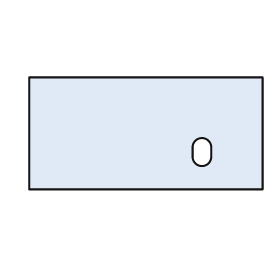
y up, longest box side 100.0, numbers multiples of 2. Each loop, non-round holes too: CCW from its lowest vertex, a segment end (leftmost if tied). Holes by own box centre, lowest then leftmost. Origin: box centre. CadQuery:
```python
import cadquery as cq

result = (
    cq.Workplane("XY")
    .moveTo(-50.0, -24.0)
    .lineTo(50.0, -24.0)
    .lineTo(50.0, 24.0)
    .lineTo(-50.0, 24.0)
    .close()
    .moveTo(20.0, -10.0)
    .threePointArc((24.0, -14.0), (28.0, -10.0))
    .lineTo(28.0, -6.0)
    .threePointArc((24.0, -2.0), (20.0, -6.0))
    .close()
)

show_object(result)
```